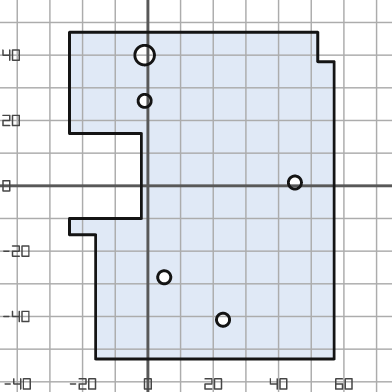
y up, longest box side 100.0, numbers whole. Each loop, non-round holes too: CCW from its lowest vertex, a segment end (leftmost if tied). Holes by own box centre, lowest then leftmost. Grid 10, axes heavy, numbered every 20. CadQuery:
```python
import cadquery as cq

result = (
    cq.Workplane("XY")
    .moveTo(-16.0, -53.0)
    .lineTo(57.0, -53.0)
    .lineTo(57.0, 38.0)
    .lineTo(52.0, 38.0)
    .lineTo(52.0, 47.0)
    .lineTo(-24.0, 47.0)
    .lineTo(-24.0, 16.0)
    .lineTo(-2.0, 16.0)
    .lineTo(-2.0, -10.0)
    .lineTo(-24.0, -10.0)
    .lineTo(-24.0, -15.0)
    .lineTo(-16.0, -15.0)
    .close()
    .moveTo(23.0, -41.0)
    .circle(2.0)
    .moveTo(5.0, -28.0)
    .circle(2.0)
    .moveTo(45.0, 1.0)
    .circle(2.0)
    .moveTo(-1.0, 26.0)
    .circle(2.0)
    .moveTo(-1.0, 40.0)
    .circle(3.0)
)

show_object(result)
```